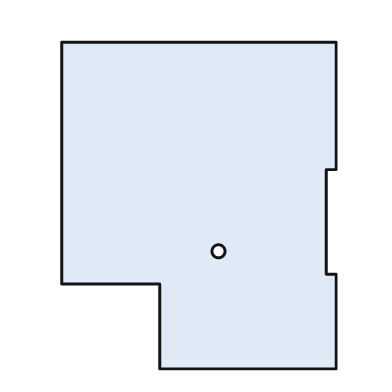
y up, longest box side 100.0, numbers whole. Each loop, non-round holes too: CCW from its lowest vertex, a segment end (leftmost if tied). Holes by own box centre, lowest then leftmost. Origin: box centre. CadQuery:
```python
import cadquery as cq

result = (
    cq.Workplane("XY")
    .moveTo(-12.0, -50.0)
    .lineTo(42.0, -50.0)
    .lineTo(42.0, -21.0)
    .lineTo(39.0, -21.0)
    .lineTo(39.0, 11.0)
    .lineTo(42.0, 11.0)
    .lineTo(42.0, 50.0)
    .lineTo(-42.0, 50.0)
    .lineTo(-42.0, -24.0)
    .lineTo(-12.0, -24.0)
    .close()
    .moveTo(6.0, -14.0)
    .circle(2.0)
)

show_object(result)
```